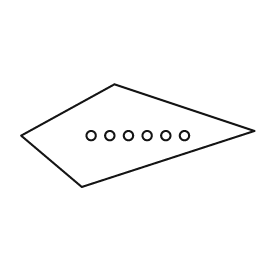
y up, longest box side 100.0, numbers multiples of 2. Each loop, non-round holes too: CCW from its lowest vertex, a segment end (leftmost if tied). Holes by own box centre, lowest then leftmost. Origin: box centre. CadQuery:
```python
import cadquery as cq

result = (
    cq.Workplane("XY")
    .moveTo(-24.0, -22.0)
    .lineTo(50.0, 2.0)
    .lineTo(-10.0, 22.0)
    .lineTo(-50.0, 0.0)
    .close()
    .moveTo(-20.0, 0.0)
    .circle(2.0)
    .moveTo(-12.0, 0.0)
    .circle(2.0)
    .moveTo(-4.0, 0.0)
    .circle(2.0)
    .moveTo(4.0, 0.0)
    .circle(2.0)
    .moveTo(12.0, 0.0)
    .circle(2.0)
    .moveTo(20.0, 0.0)
    .circle(2.0)
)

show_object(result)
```